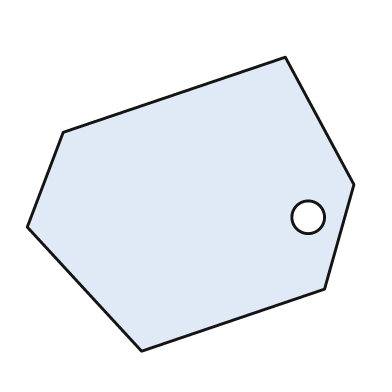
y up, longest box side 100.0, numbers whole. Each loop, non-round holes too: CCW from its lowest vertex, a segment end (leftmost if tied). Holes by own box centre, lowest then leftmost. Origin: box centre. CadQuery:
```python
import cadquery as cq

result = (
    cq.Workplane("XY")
    .moveTo(-15.0, -45.0)
    .lineTo(41.0, -26.0)
    .lineTo(50.0, 6.0)
    .lineTo(29.0, 45.0)
    .lineTo(-39.0, 22.0)
    .lineTo(-50.0, -7.0)
    .close()
    .moveTo(36.0, -4.0)
    .circle(5.0)
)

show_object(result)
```